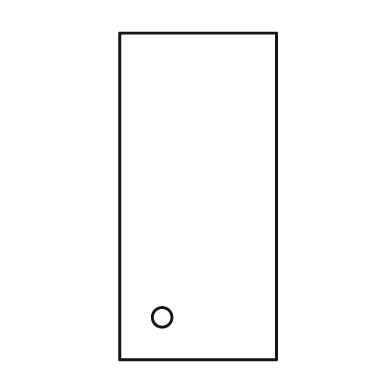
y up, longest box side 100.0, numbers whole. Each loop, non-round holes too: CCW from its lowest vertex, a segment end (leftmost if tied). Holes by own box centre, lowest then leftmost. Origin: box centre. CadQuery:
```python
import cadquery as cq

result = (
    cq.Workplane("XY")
    .moveTo(-24.0, -50.0)
    .lineTo(24.0, -50.0)
    .lineTo(24.0, 50.0)
    .lineTo(-24.0, 50.0)
    .close()
    .moveTo(-11.0, -37.0)
    .circle(3.0)
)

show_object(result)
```